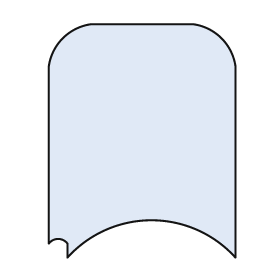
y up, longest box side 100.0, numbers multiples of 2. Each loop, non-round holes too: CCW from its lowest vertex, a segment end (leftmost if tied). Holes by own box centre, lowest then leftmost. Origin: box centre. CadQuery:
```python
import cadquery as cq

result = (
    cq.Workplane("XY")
    .moveTo(-32.0, -50.0)
    .threePointArc((4.0, -34.0), (40.0, -50.0))
    .lineTo(40.0, 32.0)
    .threePointArc((34.0, 44.0), (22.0, 50.0))
    .lineTo(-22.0, 50.0)
    .threePointArc((-34.0, 44.0), (-40.0, 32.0))
    .lineTo(-40.0, -44.0)
    .threePointArc((-36.0, -42.0), (-32.0, -44.0))
    .close()
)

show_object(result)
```